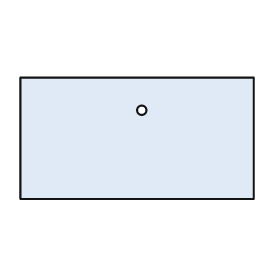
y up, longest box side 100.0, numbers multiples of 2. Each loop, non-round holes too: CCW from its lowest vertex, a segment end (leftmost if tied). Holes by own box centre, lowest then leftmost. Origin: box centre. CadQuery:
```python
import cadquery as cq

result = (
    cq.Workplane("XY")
    .moveTo(-50.0, -26.0)
    .lineTo(50.0, -26.0)
    .lineTo(50.0, 26.0)
    .lineTo(-50.0, 26.0)
    .close()
    .moveTo(2.0, 12.0)
    .circle(2.0)
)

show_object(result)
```